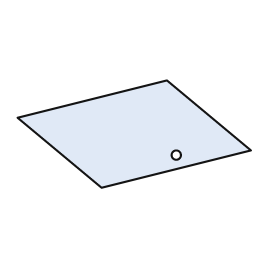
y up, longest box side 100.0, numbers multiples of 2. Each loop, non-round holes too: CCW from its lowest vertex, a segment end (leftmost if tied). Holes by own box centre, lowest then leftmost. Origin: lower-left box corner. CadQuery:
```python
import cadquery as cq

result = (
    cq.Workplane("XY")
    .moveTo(36.0, 0.0)
    .lineTo(100.0, 16.0)
    .lineTo(64.0, 46.0)
    .lineTo(0.0, 30.0)
    .close()
    .moveTo(68.0, 14.0)
    .circle(2.0)
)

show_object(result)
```